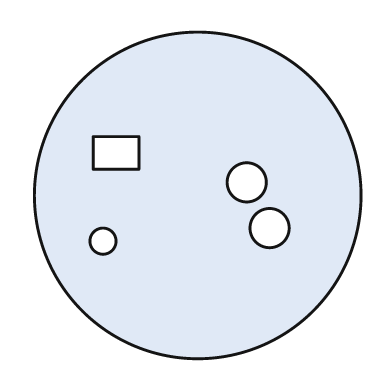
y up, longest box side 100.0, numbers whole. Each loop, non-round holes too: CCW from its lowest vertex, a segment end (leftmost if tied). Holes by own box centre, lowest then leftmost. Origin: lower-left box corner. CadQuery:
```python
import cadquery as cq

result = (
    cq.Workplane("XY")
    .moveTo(50.0, 50.0)
    .circle(50.0)
    .moveTo(21.0, 36.0)
    .circle(4.0)
    .moveTo(72.0, 40.0)
    .circle(6.0)
    .moveTo(65.0, 54.0)
    .circle(6.0)
    .moveTo(18.0, 58.0)
    .lineTo(32.0, 58.0)
    .lineTo(32.0, 68.0)
    .lineTo(18.0, 68.0)
    .close()
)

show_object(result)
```